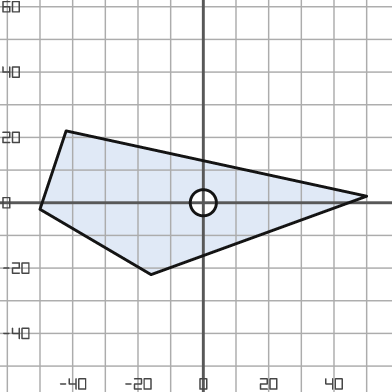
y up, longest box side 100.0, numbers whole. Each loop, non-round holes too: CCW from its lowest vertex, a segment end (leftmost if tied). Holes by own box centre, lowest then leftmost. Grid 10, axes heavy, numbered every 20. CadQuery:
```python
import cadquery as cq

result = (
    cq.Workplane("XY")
    .moveTo(-16.0, -22.0)
    .lineTo(50.0, 2.0)
    .lineTo(-42.0, 22.0)
    .lineTo(-50.0, -2.0)
    .close()
    .moveTo(0.0, 0.0)
    .circle(4.0)
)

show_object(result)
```